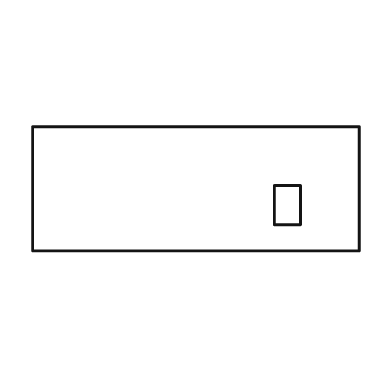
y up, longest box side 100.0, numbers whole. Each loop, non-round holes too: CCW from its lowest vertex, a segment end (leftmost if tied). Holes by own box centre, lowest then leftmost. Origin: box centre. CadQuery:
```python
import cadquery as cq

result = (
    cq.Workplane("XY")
    .moveTo(-50.0, -19.0)
    .lineTo(50.0, -19.0)
    .lineTo(50.0, 19.0)
    .lineTo(-50.0, 19.0)
    .close()
    .moveTo(24.0, -11.0)
    .lineTo(32.0, -11.0)
    .lineTo(32.0, 1.0)
    .lineTo(24.0, 1.0)
    .close()
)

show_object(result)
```